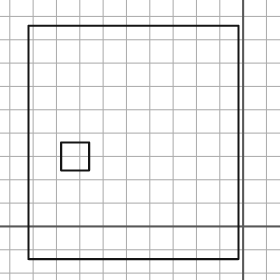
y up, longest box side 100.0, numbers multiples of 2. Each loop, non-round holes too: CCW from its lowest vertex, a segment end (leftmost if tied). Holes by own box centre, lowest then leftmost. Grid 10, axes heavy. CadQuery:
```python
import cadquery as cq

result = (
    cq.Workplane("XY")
    .moveTo(-92.0, -14.0)
    .lineTo(-2.0, -14.0)
    .lineTo(-2.0, 86.0)
    .lineTo(-92.0, 86.0)
    .close()
    .moveTo(-78.0, 24.0)
    .lineTo(-66.0, 24.0)
    .lineTo(-66.0, 36.0)
    .lineTo(-78.0, 36.0)
    .close()
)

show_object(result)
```